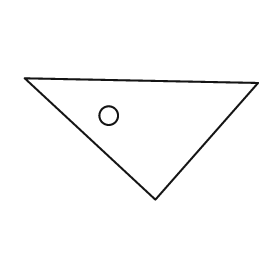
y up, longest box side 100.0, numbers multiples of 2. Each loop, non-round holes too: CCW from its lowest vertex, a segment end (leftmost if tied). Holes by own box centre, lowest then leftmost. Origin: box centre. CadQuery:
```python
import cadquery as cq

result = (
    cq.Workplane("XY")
    .moveTo(6.0, -26.0)
    .lineTo(50.0, 24.0)
    .lineTo(-50.0, 26.0)
    .close()
    .moveTo(-14.0, 10.0)
    .circle(4.0)
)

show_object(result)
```